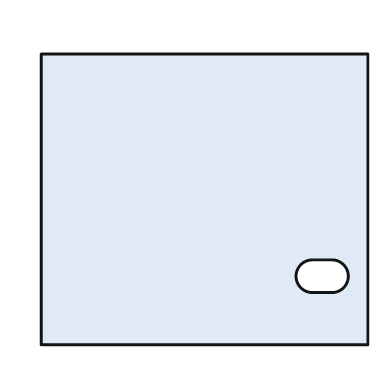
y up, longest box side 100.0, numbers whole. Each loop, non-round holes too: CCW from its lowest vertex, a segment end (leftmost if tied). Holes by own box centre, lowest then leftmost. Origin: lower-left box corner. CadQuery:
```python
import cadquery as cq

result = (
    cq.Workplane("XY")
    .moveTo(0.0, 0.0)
    .lineTo(100.0, 0.0)
    .lineTo(100.0, 89.0)
    .lineTo(0.0, 89.0)
    .close()
    .moveTo(83.0, 16.0)
    .lineTo(89.0, 16.0)
    .threePointArc((94.0, 21.0), (89.0, 26.0))
    .lineTo(83.0, 26.0)
    .threePointArc((78.0, 21.0), (83.0, 16.0))
    .close()
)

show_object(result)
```